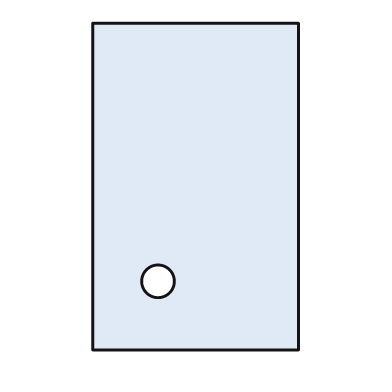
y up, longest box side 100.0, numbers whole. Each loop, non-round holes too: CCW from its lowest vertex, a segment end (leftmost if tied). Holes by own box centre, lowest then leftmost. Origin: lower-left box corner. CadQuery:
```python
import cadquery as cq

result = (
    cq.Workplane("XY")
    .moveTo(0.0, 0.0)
    .lineTo(63.0, 0.0)
    .lineTo(63.0, 100.0)
    .lineTo(0.0, 100.0)
    .close()
    .moveTo(20.0, 21.0)
    .circle(5.0)
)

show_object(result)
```